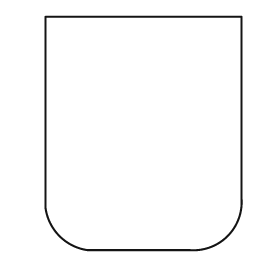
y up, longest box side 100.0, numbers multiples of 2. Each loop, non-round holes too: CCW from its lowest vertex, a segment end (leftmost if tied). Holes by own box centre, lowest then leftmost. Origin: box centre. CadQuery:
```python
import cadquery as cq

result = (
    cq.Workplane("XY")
    .moveTo(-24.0, -50.0)
    .lineTo(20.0, -50.0)
    .threePointArc((36.0, -44.0), (42.0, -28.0))
    .lineTo(42.0, 50.0)
    .lineTo(-42.0, 50.0)
    .lineTo(-42.0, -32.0)
    .threePointArc((-36.0, -44.0), (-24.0, -50.0))
    .close()
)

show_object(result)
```